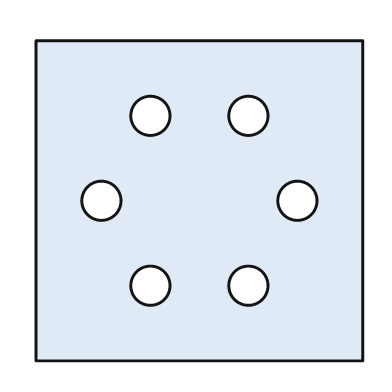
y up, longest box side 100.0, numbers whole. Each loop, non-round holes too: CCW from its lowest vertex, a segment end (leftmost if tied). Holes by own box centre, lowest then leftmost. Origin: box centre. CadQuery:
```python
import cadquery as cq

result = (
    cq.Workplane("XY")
    .moveTo(-50.0, -49.0)
    .lineTo(50.0, -49.0)
    .lineTo(50.0, 49.0)
    .lineTo(-50.0, 49.0)
    .close()
    .moveTo(-15.0, -26.0)
    .circle(6.0)
    .moveTo(15.0, -26.0)
    .circle(6.0)
    .moveTo(-30.0, 0.0)
    .circle(6.0)
    .moveTo(30.0, 0.0)
    .circle(6.0)
    .moveTo(-15.0, 26.0)
    .circle(6.0)
    .moveTo(15.0, 26.0)
    .circle(6.0)
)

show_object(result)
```